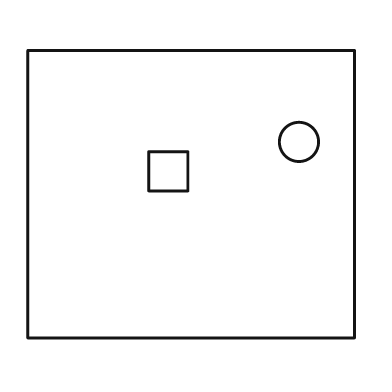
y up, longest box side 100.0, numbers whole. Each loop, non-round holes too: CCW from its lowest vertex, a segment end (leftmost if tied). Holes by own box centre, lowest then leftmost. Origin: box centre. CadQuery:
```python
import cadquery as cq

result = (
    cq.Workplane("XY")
    .moveTo(-50.0, -44.0)
    .lineTo(50.0, -44.0)
    .lineTo(50.0, 44.0)
    .lineTo(-50.0, 44.0)
    .close()
    .moveTo(-13.0, 1.0)
    .lineTo(-1.0, 1.0)
    .lineTo(-1.0, 13.0)
    .lineTo(-13.0, 13.0)
    .close()
    .moveTo(33.0, 16.0)
    .circle(6.0)
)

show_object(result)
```